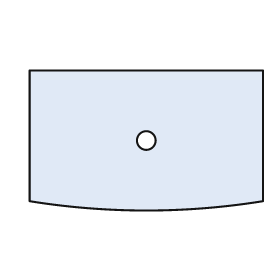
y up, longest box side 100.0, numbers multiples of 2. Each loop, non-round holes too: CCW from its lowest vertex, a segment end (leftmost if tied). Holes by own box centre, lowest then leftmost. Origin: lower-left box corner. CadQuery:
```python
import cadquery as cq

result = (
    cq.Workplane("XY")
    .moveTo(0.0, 4.0)
    .threePointArc((50.0, 0.0), (100.0, 4.0))
    .lineTo(100.0, 60.0)
    .lineTo(0.0, 60.0)
    .close()
    .moveTo(50.0, 30.0)
    .circle(4.0)
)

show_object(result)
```